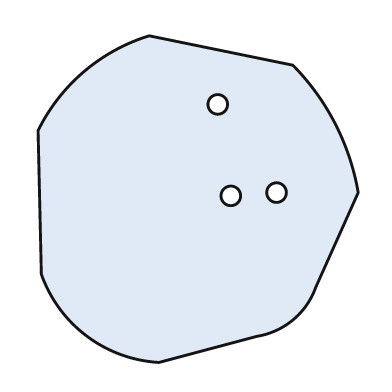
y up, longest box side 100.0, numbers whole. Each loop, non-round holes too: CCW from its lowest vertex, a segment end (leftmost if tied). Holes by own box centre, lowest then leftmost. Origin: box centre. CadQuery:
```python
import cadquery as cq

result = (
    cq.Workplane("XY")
    .moveTo(-12.0, -50.0)
    .lineTo(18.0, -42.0)
    .threePointArc((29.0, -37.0), (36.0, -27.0))
    .lineTo(49.0, 2.0)
    .threePointArc((42.0, 23.0), (29.0, 41.0))
    .lineTo(-15.0, 50.0)
    .threePointArc((-35.0, 39.0), (-49.0, 21.0))
    .lineTo(-48.0, -23.0)
    .threePointArc((-34.0, -42.0), (-12.0, -50.0))
    .close()
    .moveTo(10.0, 1.0)
    .circle(3.0)
    .moveTo(24.0, 2.0)
    .circle(3.0)
    .moveTo(6.0, 29.0)
    .circle(3.0)
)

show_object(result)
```